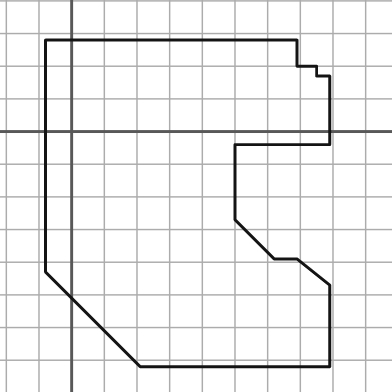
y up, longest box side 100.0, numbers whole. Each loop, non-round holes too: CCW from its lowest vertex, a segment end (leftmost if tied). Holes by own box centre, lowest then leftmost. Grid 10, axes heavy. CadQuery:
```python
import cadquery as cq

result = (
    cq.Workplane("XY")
    .moveTo(21.0, -72.0)
    .lineTo(79.0, -72.0)
    .lineTo(79.0, -47.0)
    .lineTo(69.0, -39.0)
    .lineTo(62.0, -39.0)
    .lineTo(50.0, -27.0)
    .lineTo(50.0, -4.0)
    .lineTo(79.0, -4.0)
    .lineTo(79.0, 17.0)
    .lineTo(75.0, 17.0)
    .lineTo(75.0, 20.0)
    .lineTo(69.0, 20.0)
    .lineTo(69.0, 28.0)
    .lineTo(-8.0, 28.0)
    .lineTo(-8.0, -43.0)
    .close()
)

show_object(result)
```